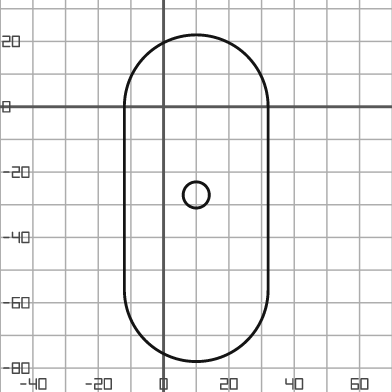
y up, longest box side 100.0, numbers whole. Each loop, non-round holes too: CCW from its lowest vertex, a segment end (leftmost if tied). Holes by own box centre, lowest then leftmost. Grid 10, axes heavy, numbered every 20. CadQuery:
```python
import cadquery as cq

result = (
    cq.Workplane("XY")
    .moveTo(-12.0, -56.0)
    .threePointArc((10.0, -78.0), (32.0, -56.0))
    .lineTo(32.0, 0.0)
    .threePointArc((10.0, 22.0), (-12.0, 0.0))
    .close()
    .moveTo(10.0, -27.0)
    .circle(4.0)
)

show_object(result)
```